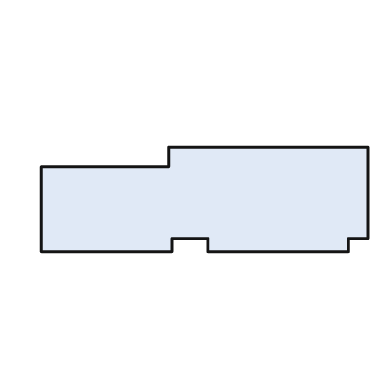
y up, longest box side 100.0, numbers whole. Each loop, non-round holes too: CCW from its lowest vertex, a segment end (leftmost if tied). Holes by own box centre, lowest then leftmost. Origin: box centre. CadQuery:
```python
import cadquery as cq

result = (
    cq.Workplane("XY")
    .moveTo(-50.0, -16.0)
    .lineTo(-10.0, -16.0)
    .lineTo(-10.0, -12.0)
    .lineTo(1.0, -12.0)
    .lineTo(1.0, -16.0)
    .lineTo(44.0, -16.0)
    .lineTo(44.0, -12.0)
    .lineTo(50.0, -12.0)
    .lineTo(50.0, 16.0)
    .lineTo(-11.0, 16.0)
    .lineTo(-11.0, 10.0)
    .lineTo(-50.0, 10.0)
    .close()
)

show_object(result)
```